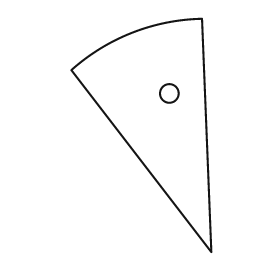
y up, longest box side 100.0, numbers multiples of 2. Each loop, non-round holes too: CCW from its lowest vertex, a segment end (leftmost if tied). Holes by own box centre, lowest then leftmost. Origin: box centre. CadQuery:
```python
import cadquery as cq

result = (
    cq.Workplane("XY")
    .moveTo(30.0, -50.0)
    .lineTo(26.0, 50.0)
    .threePointArc((-4.0, 44.0), (-30.0, 28.0))
    .close()
    .moveTo(12.0, 18.0)
    .circle(4.0)
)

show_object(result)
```